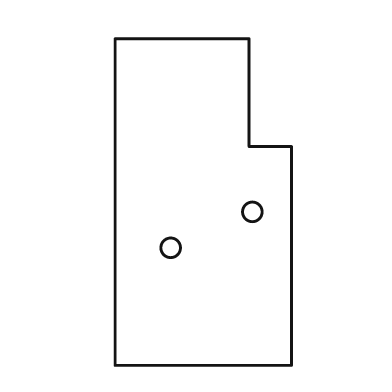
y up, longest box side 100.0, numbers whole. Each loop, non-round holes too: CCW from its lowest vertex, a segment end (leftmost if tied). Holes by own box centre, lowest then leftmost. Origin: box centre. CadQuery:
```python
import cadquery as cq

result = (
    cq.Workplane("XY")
    .moveTo(-27.0, -50.0)
    .lineTo(27.0, -50.0)
    .lineTo(27.0, 17.0)
    .lineTo(14.0, 17.0)
    .lineTo(14.0, 50.0)
    .lineTo(-27.0, 50.0)
    .close()
    .moveTo(-10.0, -14.0)
    .circle(3.0)
    .moveTo(15.0, -3.0)
    .circle(3.0)
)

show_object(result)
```